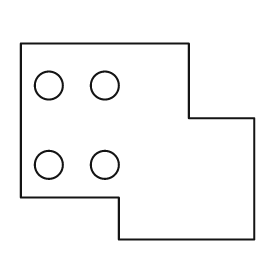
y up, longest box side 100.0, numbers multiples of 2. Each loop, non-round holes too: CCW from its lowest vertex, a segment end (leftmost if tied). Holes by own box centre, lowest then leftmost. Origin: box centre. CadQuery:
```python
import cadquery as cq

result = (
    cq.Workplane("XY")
    .moveTo(-8.0, -42.0)
    .lineTo(50.0, -42.0)
    .lineTo(50.0, 10.0)
    .lineTo(22.0, 10.0)
    .lineTo(22.0, 42.0)
    .lineTo(-50.0, 42.0)
    .lineTo(-50.0, -24.0)
    .lineTo(-8.0, -24.0)
    .close()
    .moveTo(-38.0, -10.0)
    .circle(6.0)
    .moveTo(-14.0, -10.0)
    .circle(6.0)
    .moveTo(-38.0, 24.0)
    .circle(6.0)
    .moveTo(-14.0, 24.0)
    .circle(6.0)
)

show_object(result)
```